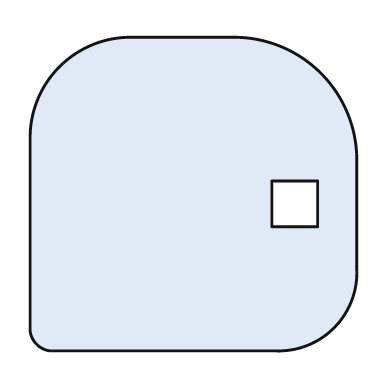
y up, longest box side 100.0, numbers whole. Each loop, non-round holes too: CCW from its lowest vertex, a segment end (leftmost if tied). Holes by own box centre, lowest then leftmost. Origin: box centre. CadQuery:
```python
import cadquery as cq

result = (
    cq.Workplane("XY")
    .moveTo(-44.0, -48.0)
    .lineTo(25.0, -48.0)
    .threePointArc((43.0, -41.0), (50.0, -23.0))
    .lineTo(50.0, 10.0)
    .threePointArc((39.0, 37.0), (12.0, 48.0))
    .lineTo(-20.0, 48.0)
    .threePointArc((-41.0, 39.0), (-50.0, 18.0))
    .lineTo(-50.0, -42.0)
    .threePointArc((-48.0, -46.0), (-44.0, -48.0))
    .close()
    .moveTo(24.0, -10.0)
    .lineTo(38.0, -10.0)
    .lineTo(38.0, 4.0)
    .lineTo(24.0, 4.0)
    .close()
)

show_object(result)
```